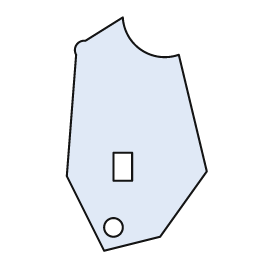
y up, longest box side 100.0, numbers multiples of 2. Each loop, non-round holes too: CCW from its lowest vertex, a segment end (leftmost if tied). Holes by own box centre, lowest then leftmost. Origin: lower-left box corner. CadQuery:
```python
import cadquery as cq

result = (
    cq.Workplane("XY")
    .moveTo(16.0, 0.0)
    .lineTo(40.0, 6.0)
    .lineTo(60.0, 34.0)
    .lineTo(48.0, 84.0)
    .threePointArc((32.0, 86.0), (24.0, 100.0))
    .lineTo(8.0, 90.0)
    .threePointArc((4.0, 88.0), (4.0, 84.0))
    .lineTo(0.0, 32.0)
    .close()
    .moveTo(20.0, 10.0)
    .circle(4.0)
    .moveTo(20.0, 30.0)
    .lineTo(28.0, 30.0)
    .lineTo(28.0, 42.0)
    .lineTo(20.0, 42.0)
    .close()
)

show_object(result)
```